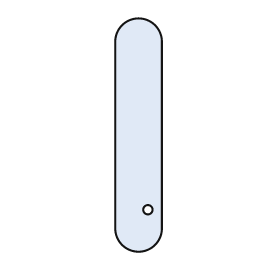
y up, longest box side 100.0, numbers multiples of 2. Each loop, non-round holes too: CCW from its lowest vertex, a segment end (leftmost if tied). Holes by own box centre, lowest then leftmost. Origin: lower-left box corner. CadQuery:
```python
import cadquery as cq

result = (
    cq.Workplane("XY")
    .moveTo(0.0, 10.0)
    .threePointArc((10.0, 0.0), (20.0, 10.0))
    .lineTo(20.0, 90.0)
    .threePointArc((10.0, 100.0), (0.0, 90.0))
    .close()
    .moveTo(14.0, 18.0)
    .circle(2.0)
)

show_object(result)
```